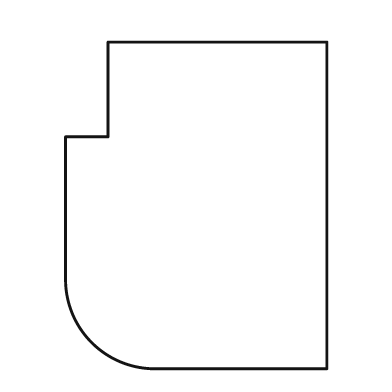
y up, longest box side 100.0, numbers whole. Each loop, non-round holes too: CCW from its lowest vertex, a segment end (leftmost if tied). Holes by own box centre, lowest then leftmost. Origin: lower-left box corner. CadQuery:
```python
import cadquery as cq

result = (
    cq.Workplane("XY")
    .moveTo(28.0, 0.0)
    .lineTo(80.0, 0.0)
    .lineTo(80.0, 100.0)
    .lineTo(13.0, 100.0)
    .lineTo(13.0, 71.0)
    .lineTo(0.0, 71.0)
    .lineTo(0.0, 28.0)
    .threePointArc((8.0, 8.0), (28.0, 0.0))
    .close()
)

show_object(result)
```